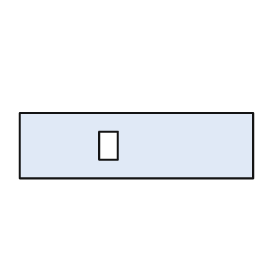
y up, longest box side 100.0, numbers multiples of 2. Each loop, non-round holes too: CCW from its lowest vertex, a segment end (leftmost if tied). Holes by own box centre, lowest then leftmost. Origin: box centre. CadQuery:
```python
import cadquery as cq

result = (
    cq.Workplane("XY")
    .moveTo(-50.0, -14.0)
    .lineTo(50.0, -14.0)
    .lineTo(50.0, 14.0)
    .lineTo(-50.0, 14.0)
    .close()
    .moveTo(-16.0, -6.0)
    .lineTo(-8.0, -6.0)
    .lineTo(-8.0, 6.0)
    .lineTo(-16.0, 6.0)
    .close()
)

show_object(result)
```